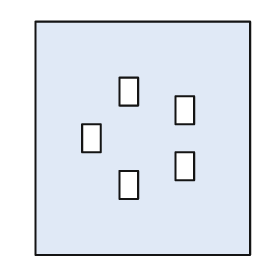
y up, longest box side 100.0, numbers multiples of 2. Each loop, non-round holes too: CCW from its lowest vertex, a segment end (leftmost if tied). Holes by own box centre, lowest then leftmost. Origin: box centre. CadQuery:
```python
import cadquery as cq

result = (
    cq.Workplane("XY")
    .moveTo(-46.0, -50.0)
    .lineTo(46.0, -50.0)
    .lineTo(46.0, 50.0)
    .lineTo(-46.0, 50.0)
    .close()
    .moveTo(-10.0, -26.0)
    .lineTo(-2.0, -26.0)
    .lineTo(-2.0, -14.0)
    .lineTo(-10.0, -14.0)
    .close()
    .moveTo(14.0, -18.0)
    .lineTo(22.0, -18.0)
    .lineTo(22.0, -6.0)
    .lineTo(14.0, -6.0)
    .close()
    .moveTo(-26.0, -6.0)
    .lineTo(-18.0, -6.0)
    .lineTo(-18.0, 6.0)
    .lineTo(-26.0, 6.0)
    .close()
    .moveTo(14.0, 6.0)
    .lineTo(22.0, 6.0)
    .lineTo(22.0, 18.0)
    .lineTo(14.0, 18.0)
    .close()
    .moveTo(-10.0, 14.0)
    .lineTo(-2.0, 14.0)
    .lineTo(-2.0, 26.0)
    .lineTo(-10.0, 26.0)
    .close()
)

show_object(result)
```